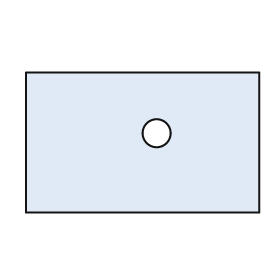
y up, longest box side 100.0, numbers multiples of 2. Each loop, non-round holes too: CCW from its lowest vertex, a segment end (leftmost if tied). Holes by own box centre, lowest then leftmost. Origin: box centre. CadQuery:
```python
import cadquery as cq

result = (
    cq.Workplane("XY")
    .moveTo(-50.0, -30.0)
    .lineTo(50.0, -30.0)
    .lineTo(50.0, 30.0)
    .lineTo(-50.0, 30.0)
    .close()
    .moveTo(6.0, 4.0)
    .circle(6.0)
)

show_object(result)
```